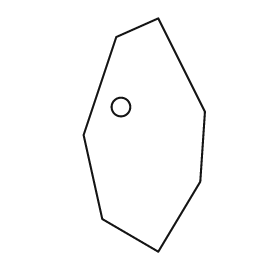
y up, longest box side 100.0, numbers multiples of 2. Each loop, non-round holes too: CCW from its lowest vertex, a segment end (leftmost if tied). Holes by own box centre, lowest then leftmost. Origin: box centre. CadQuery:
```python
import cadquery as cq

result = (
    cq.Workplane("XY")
    .moveTo(6.0, -50.0)
    .lineTo(24.0, -20.0)
    .lineTo(26.0, 10.0)
    .lineTo(6.0, 50.0)
    .lineTo(-12.0, 42.0)
    .lineTo(-26.0, 0.0)
    .lineTo(-18.0, -36.0)
    .close()
    .moveTo(-10.0, 12.0)
    .circle(4.0)
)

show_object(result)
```